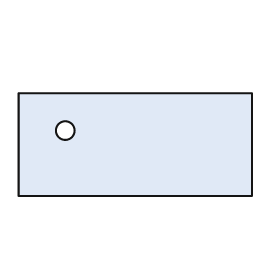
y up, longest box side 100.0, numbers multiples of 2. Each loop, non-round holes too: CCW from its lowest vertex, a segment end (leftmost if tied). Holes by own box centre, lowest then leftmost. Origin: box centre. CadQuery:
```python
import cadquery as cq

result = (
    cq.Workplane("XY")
    .moveTo(-50.0, -22.0)
    .lineTo(50.0, -22.0)
    .lineTo(50.0, 22.0)
    .lineTo(-50.0, 22.0)
    .close()
    .moveTo(-30.0, 6.0)
    .circle(4.0)
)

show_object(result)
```